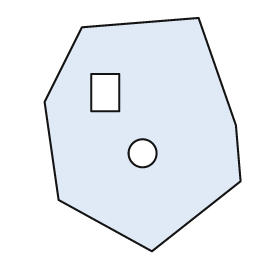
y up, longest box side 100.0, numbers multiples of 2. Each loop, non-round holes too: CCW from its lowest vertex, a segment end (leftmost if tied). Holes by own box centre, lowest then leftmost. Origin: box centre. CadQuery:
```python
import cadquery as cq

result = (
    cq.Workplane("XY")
    .moveTo(4.0, -50.0)
    .lineTo(42.0, -20.0)
    .lineTo(40.0, 4.0)
    .lineTo(24.0, 50.0)
    .lineTo(-26.0, 46.0)
    .lineTo(-42.0, 14.0)
    .lineTo(-36.0, -28.0)
    .close()
    .moveTo(0.0, -8.0)
    .circle(6.0)
    .moveTo(-22.0, 10.0)
    .lineTo(-10.0, 10.0)
    .lineTo(-10.0, 26.0)
    .lineTo(-22.0, 26.0)
    .close()
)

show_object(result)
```